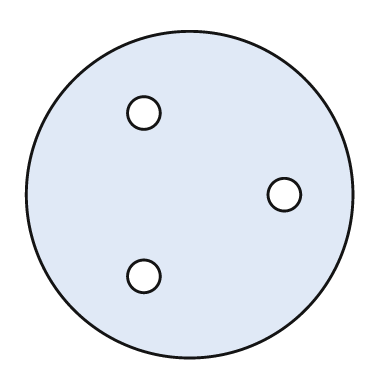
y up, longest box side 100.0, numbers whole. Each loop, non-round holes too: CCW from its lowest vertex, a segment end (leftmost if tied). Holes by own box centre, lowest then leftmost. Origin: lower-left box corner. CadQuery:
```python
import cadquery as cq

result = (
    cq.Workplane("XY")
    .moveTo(50.0, 50.0)
    .circle(50.0)
    .moveTo(36.0, 25.0)
    .circle(5.0)
    .moveTo(79.0, 50.0)
    .circle(5.0)
    .moveTo(36.0, 75.0)
    .circle(5.0)
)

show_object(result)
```